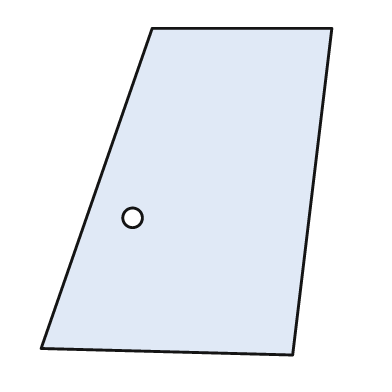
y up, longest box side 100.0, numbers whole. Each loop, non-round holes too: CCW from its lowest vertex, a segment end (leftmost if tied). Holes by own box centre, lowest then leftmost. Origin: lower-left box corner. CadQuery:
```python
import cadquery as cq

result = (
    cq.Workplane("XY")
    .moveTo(77.0, 0.0)
    .lineTo(89.0, 100.0)
    .lineTo(34.0, 100.0)
    .lineTo(0.0, 2.0)
    .close()
    .moveTo(28.0, 42.0)
    .circle(3.0)
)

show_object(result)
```